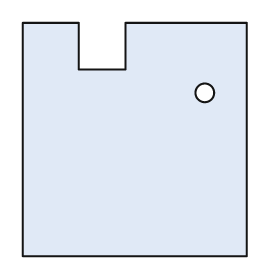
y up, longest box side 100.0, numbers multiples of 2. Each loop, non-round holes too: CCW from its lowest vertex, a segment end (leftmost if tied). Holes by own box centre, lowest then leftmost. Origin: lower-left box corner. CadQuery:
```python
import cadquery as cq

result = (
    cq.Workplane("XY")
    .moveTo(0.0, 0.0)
    .lineTo(96.0, 0.0)
    .lineTo(96.0, 100.0)
    .lineTo(44.0, 100.0)
    .lineTo(44.0, 80.0)
    .lineTo(24.0, 80.0)
    .lineTo(24.0, 100.0)
    .lineTo(0.0, 100.0)
    .close()
    .moveTo(78.0, 70.0)
    .circle(4.0)
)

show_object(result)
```